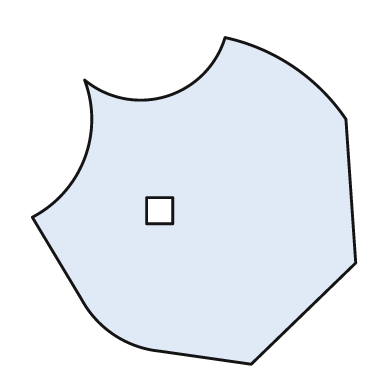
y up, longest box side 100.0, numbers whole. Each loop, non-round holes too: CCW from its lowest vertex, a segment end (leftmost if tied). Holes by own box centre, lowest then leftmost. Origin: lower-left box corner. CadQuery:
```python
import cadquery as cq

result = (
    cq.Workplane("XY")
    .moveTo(67.0, 0.0)
    .lineTo(99.0, 31.0)
    .lineTo(96.0, 75.0)
    .threePointArc((80.0, 91.0), (59.0, 100.0))
    .threePointArc((41.0, 82.0), (16.0, 87.0))
    .threePointArc((16.0, 63.0), (0.0, 45.0))
    .lineTo(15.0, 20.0)
    .threePointArc((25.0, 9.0), (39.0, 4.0))
    .close()
    .moveTo(35.0, 43.0)
    .lineTo(43.0, 43.0)
    .lineTo(43.0, 51.0)
    .lineTo(35.0, 51.0)
    .close()
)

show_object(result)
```